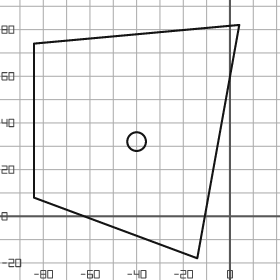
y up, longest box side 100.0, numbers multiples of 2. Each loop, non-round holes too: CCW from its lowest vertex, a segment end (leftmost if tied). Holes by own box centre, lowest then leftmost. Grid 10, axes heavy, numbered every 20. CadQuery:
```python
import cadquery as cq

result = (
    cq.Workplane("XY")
    .moveTo(-14.0, -18.0)
    .lineTo(4.0, 82.0)
    .lineTo(-84.0, 74.0)
    .lineTo(-84.0, 8.0)
    .close()
    .moveTo(-40.0, 32.0)
    .circle(4.0)
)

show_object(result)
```